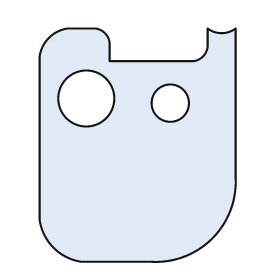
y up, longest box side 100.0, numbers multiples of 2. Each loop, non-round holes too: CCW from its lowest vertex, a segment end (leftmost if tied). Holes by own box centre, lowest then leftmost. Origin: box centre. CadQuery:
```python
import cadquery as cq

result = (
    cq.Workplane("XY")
    .moveTo(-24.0, -50.0)
    .lineTo(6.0, -50.0)
    .threePointArc((32.0, -40.0), (42.0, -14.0))
    .lineTo(42.0, 50.0)
    .threePointArc((36.0, 48.0), (30.0, 50.0))
    .lineTo(30.0, 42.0)
    .threePointArc((28.0, 38.0), (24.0, 36.0))
    .lineTo(-12.0, 36.0)
    .lineTo(-12.0, 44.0)
    .threePointArc((-14.0, 48.0), (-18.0, 50.0))
    .lineTo(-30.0, 50.0)
    .threePointArc((-38.0, 46.0), (-42.0, 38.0))
    .lineTo(-42.0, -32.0)
    .threePointArc((-36.0, -44.0), (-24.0, -50.0))
    .close()
    .moveTo(14.0, 18.0)
    .circle(8.0)
    .moveTo(-22.0, 20.0)
    .circle(12.0)
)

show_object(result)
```